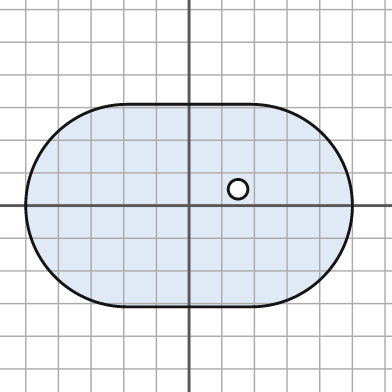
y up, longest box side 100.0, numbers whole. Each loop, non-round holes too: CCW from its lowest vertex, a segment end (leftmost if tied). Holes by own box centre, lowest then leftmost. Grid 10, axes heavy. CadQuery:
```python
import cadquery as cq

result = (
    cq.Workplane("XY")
    .moveTo(-19.0, -31.0)
    .lineTo(19.0, -31.0)
    .threePointArc((50.0, 0.0), (19.0, 31.0))
    .lineTo(-19.0, 31.0)
    .threePointArc((-50.0, 0.0), (-19.0, -31.0))
    .close()
    .moveTo(15.0, 5.0)
    .circle(3.0)
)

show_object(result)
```